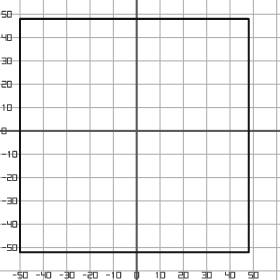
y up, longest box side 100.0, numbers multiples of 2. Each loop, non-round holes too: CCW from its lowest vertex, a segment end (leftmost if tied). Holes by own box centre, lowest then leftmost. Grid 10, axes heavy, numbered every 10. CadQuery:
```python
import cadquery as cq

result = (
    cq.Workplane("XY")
    .moveTo(-50.0, -52.0)
    .lineTo(48.0, -52.0)
    .lineTo(48.0, 48.0)
    .lineTo(-50.0, 48.0)
    .close()
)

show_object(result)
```